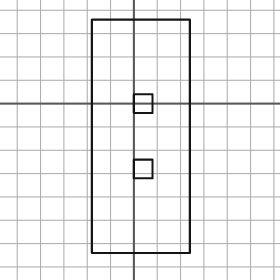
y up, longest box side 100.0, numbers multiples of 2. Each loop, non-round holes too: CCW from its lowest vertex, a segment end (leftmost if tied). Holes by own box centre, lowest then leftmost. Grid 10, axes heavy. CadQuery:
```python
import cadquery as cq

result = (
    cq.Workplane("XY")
    .moveTo(-18.0, -64.0)
    .lineTo(24.0, -64.0)
    .lineTo(24.0, 36.0)
    .lineTo(-18.0, 36.0)
    .close()
    .moveTo(0.0, -32.0)
    .lineTo(8.0, -32.0)
    .lineTo(8.0, -24.0)
    .lineTo(0.0, -24.0)
    .close()
    .moveTo(0.0, -4.0)
    .lineTo(8.0, -4.0)
    .lineTo(8.0, 4.0)
    .lineTo(0.0, 4.0)
    .close()
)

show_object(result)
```